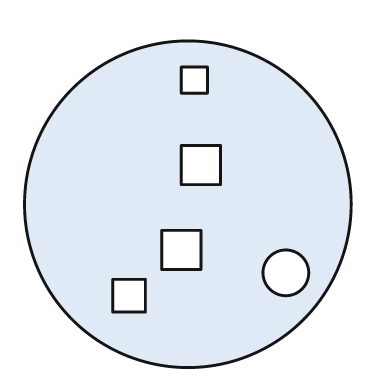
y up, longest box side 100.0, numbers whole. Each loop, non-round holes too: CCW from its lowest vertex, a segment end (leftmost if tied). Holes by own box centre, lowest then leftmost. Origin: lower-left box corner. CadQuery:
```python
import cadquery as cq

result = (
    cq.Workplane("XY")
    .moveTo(50.0, 50.0)
    .circle(50.0)
    .moveTo(27.0, 17.0)
    .lineTo(37.0, 17.0)
    .lineTo(37.0, 27.0)
    .lineTo(27.0, 27.0)
    .close()
    .moveTo(80.0, 29.0)
    .circle(7.0)
    .moveTo(42.0, 30.0)
    .lineTo(54.0, 30.0)
    .lineTo(54.0, 42.0)
    .lineTo(42.0, 42.0)
    .close()
    .moveTo(48.0, 56.0)
    .lineTo(60.0, 56.0)
    .lineTo(60.0, 68.0)
    .lineTo(48.0, 68.0)
    .close()
    .moveTo(48.0, 84.0)
    .lineTo(56.0, 84.0)
    .lineTo(56.0, 92.0)
    .lineTo(48.0, 92.0)
    .close()
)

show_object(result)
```